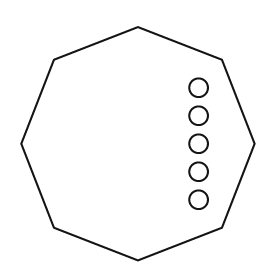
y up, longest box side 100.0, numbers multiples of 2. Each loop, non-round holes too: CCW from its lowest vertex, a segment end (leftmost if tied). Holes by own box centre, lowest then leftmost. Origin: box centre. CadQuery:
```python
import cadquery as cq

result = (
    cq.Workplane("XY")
    .moveTo(0.0, -50.0)
    .lineTo(36.0, -36.0)
    .lineTo(50.0, 0.0)
    .lineTo(36.0, 36.0)
    .lineTo(0.0, 50.0)
    .lineTo(-36.0, 36.0)
    .lineTo(-50.0, 0.0)
    .lineTo(-36.0, -36.0)
    .close()
    .moveTo(26.0, -24.0)
    .circle(4.0)
    .moveTo(26.0, -12.0)
    .circle(4.0)
    .moveTo(26.0, 0.0)
    .circle(4.0)
    .moveTo(26.0, 12.0)
    .circle(4.0)
    .moveTo(26.0, 24.0)
    .circle(4.0)
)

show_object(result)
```